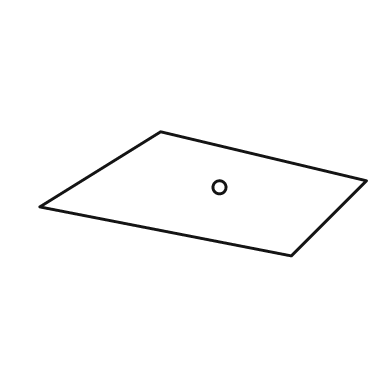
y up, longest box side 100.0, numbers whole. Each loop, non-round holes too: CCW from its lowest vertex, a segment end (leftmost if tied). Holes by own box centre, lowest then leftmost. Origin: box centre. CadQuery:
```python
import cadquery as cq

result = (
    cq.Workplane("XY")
    .moveTo(27.0, -19.0)
    .lineTo(50.0, 4.0)
    .lineTo(-13.0, 19.0)
    .lineTo(-50.0, -4.0)
    .close()
    .moveTo(5.0, 2.0)
    .circle(2.0)
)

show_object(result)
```